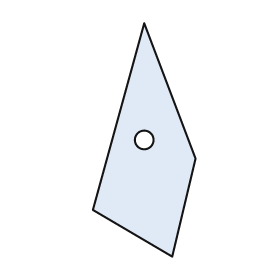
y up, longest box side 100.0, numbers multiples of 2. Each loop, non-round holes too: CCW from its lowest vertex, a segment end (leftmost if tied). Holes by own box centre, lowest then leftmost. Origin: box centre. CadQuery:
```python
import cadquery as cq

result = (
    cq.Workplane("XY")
    .moveTo(12.0, -50.0)
    .lineTo(22.0, -8.0)
    .lineTo(0.0, 50.0)
    .lineTo(-22.0, -30.0)
    .close()
    .moveTo(0.0, 0.0)
    .circle(4.0)
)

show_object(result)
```